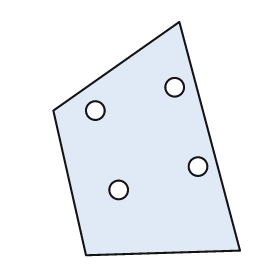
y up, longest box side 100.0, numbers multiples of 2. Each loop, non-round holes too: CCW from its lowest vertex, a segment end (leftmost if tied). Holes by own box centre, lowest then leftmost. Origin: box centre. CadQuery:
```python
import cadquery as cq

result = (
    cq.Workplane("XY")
    .moveTo(-26.0, -50.0)
    .lineTo(40.0, -48.0)
    .lineTo(14.0, 50.0)
    .lineTo(-40.0, 12.0)
    .close()
    .moveTo(-12.0, -22.0)
    .circle(4.0)
    .moveTo(22.0, -12.0)
    .circle(4.0)
    .moveTo(-22.0, 12.0)
    .circle(4.0)
    .moveTo(12.0, 22.0)
    .circle(4.0)
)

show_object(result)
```